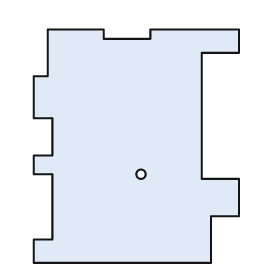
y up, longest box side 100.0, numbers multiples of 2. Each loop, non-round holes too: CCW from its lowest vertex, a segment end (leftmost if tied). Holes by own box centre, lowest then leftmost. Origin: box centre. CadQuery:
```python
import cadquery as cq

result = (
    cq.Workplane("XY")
    .moveTo(-44.0, -50.0)
    .lineTo(32.0, -50.0)
    .lineTo(32.0, -30.0)
    .lineTo(44.0, -30.0)
    .lineTo(44.0, -14.0)
    .lineTo(28.0, -14.0)
    .lineTo(28.0, 40.0)
    .lineTo(44.0, 40.0)
    .lineTo(44.0, 50.0)
    .lineTo(6.0, 50.0)
    .lineTo(6.0, 46.0)
    .lineTo(-14.0, 46.0)
    .lineTo(-14.0, 50.0)
    .lineTo(-38.0, 50.0)
    .lineTo(-38.0, 30.0)
    .lineTo(-44.0, 30.0)
    .lineTo(-44.0, 12.0)
    .lineTo(-36.0, 12.0)
    .lineTo(-36.0, -4.0)
    .lineTo(-44.0, -4.0)
    .lineTo(-44.0, -12.0)
    .lineTo(-36.0, -12.0)
    .lineTo(-36.0, -40.0)
    .lineTo(-44.0, -40.0)
    .close()
    .moveTo(2.0, -12.0)
    .circle(2.0)
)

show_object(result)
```